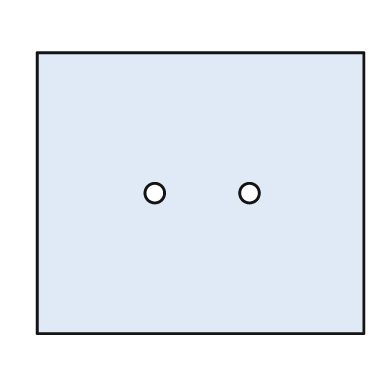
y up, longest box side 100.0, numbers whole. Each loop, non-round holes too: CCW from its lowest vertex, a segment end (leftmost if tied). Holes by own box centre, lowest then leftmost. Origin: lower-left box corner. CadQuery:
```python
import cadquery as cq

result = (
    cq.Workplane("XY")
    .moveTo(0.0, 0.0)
    .lineTo(100.0, 0.0)
    .lineTo(100.0, 86.0)
    .lineTo(0.0, 86.0)
    .close()
    .moveTo(36.0, 43.0)
    .circle(3.0)
    .moveTo(65.0, 43.0)
    .circle(3.0)
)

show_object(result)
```